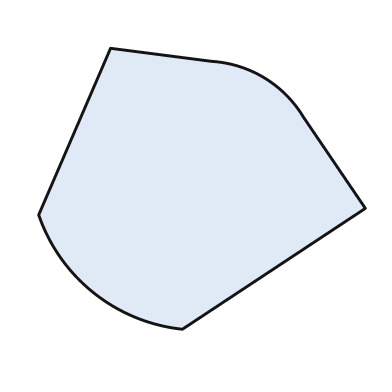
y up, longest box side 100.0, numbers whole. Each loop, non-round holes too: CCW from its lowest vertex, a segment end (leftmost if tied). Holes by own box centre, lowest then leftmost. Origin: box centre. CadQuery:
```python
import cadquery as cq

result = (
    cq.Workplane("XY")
    .moveTo(-6.0, -43.0)
    .lineTo(50.0, -6.0)
    .lineTo(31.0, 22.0)
    .threePointArc((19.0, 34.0), (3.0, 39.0))
    .lineTo(-28.0, 43.0)
    .lineTo(-50.0, -8.0)
    .threePointArc((-33.0, -32.0), (-6.0, -43.0))
    .close()
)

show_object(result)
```